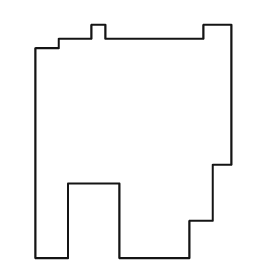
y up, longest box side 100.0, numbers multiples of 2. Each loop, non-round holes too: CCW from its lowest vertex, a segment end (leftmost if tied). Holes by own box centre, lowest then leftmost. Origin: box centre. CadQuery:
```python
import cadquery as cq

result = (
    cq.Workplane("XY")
    .moveTo(-42.0, -50.0)
    .lineTo(-28.0, -50.0)
    .lineTo(-28.0, -18.0)
    .lineTo(-6.0, -18.0)
    .lineTo(-6.0, -50.0)
    .lineTo(24.0, -50.0)
    .lineTo(24.0, -34.0)
    .lineTo(34.0, -34.0)
    .lineTo(34.0, -10.0)
    .lineTo(42.0, -10.0)
    .lineTo(42.0, 50.0)
    .lineTo(30.0, 50.0)
    .lineTo(30.0, 44.0)
    .lineTo(-12.0, 44.0)
    .lineTo(-12.0, 50.0)
    .lineTo(-18.0, 50.0)
    .lineTo(-18.0, 44.0)
    .lineTo(-32.0, 44.0)
    .lineTo(-32.0, 40.0)
    .lineTo(-42.0, 40.0)
    .close()
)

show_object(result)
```